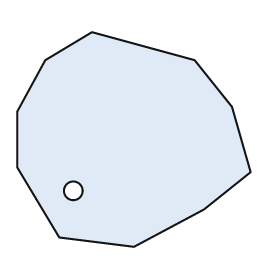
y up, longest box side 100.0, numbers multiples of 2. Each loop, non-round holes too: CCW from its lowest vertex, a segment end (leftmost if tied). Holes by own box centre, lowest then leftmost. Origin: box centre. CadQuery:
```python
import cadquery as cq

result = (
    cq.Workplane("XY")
    .moveTo(0.0, -46.0)
    .lineTo(30.0, -30.0)
    .lineTo(50.0, -14.0)
    .lineTo(42.0, 14.0)
    .lineTo(26.0, 34.0)
    .lineTo(-18.0, 46.0)
    .lineTo(-38.0, 34.0)
    .lineTo(-50.0, 12.0)
    .lineTo(-50.0, -12.0)
    .lineTo(-32.0, -42.0)
    .close()
    .moveTo(-26.0, -22.0)
    .circle(4.0)
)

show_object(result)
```